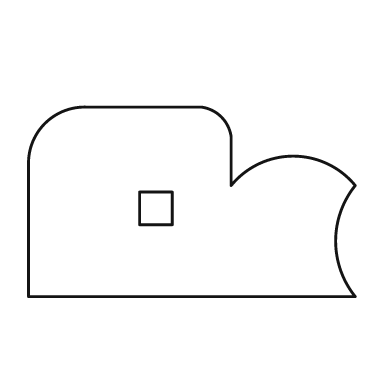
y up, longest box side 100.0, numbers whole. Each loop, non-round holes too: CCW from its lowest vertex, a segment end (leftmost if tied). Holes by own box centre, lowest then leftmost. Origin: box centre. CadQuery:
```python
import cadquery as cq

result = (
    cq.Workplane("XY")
    .moveTo(-50.0, -29.0)
    .lineTo(50.0, -29.0)
    .threePointArc((44.0, -12.0), (50.0, 5.0))
    .threePointArc((31.0, 14.0), (12.0, 5.0))
    .lineTo(12.0, 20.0)
    .threePointArc((9.0, 26.0), (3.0, 29.0))
    .lineTo(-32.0, 29.0)
    .threePointArc((-45.0, 24.0), (-50.0, 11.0))
    .close()
    .moveTo(-16.0, -7.0)
    .lineTo(-6.0, -7.0)
    .lineTo(-6.0, 3.0)
    .lineTo(-16.0, 3.0)
    .close()
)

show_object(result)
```